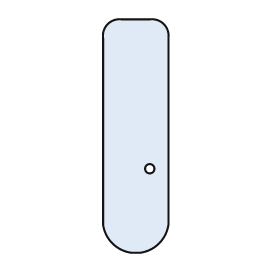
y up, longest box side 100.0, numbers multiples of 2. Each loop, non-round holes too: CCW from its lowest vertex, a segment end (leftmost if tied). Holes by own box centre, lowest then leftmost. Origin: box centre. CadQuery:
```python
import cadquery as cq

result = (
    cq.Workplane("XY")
    .moveTo(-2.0, -50.0)
    .lineTo(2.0, -50.0)
    .threePointArc((10.0, -46.0), (14.0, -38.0))
    .lineTo(14.0, 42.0)
    .threePointArc((12.0, 48.0), (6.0, 50.0))
    .lineTo(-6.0, 50.0)
    .threePointArc((-12.0, 48.0), (-14.0, 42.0))
    .lineTo(-14.0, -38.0)
    .threePointArc((-10.0, -46.0), (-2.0, -50.0))
    .close()
    .moveTo(6.0, -14.0)
    .circle(2.0)
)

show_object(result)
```